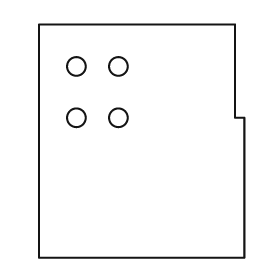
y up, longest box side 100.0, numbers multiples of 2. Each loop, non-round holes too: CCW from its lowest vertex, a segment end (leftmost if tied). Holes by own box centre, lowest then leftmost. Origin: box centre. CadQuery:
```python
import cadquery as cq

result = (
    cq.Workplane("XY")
    .moveTo(-44.0, -50.0)
    .lineTo(44.0, -50.0)
    .lineTo(44.0, 10.0)
    .lineTo(40.0, 10.0)
    .lineTo(40.0, 50.0)
    .lineTo(-44.0, 50.0)
    .close()
    .moveTo(-28.0, 10.0)
    .circle(4.0)
    .moveTo(-10.0, 10.0)
    .circle(4.0)
    .moveTo(-28.0, 32.0)
    .circle(4.0)
    .moveTo(-10.0, 32.0)
    .circle(4.0)
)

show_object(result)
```